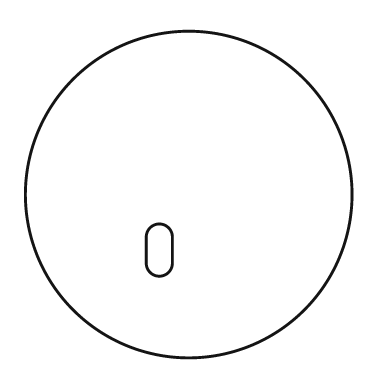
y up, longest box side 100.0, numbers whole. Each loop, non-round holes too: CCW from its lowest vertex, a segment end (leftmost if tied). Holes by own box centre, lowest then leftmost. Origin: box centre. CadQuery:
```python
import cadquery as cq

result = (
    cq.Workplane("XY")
    .moveTo(0.0, 0.0)
    .circle(50.0)
    .moveTo(-13.0, -21.0)
    .threePointArc((-9.0, -25.0), (-5.0, -21.0))
    .lineTo(-5.0, -13.0)
    .threePointArc((-9.0, -9.0), (-13.0, -13.0))
    .close()
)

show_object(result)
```